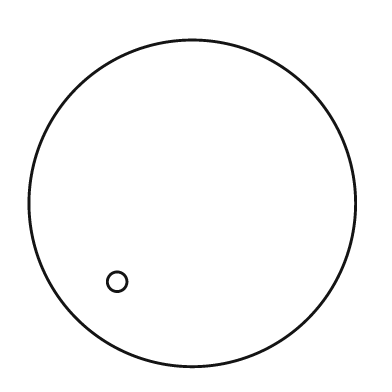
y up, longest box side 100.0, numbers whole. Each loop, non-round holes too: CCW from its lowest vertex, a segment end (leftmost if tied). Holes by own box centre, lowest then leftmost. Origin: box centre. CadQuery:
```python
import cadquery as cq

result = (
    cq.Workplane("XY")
    .moveTo(0.0, 0.0)
    .circle(50.0)
    .moveTo(-23.0, -24.0)
    .circle(3.0)
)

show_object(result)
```